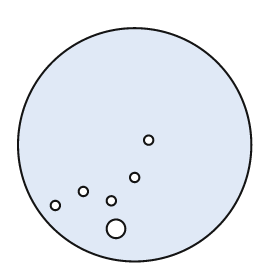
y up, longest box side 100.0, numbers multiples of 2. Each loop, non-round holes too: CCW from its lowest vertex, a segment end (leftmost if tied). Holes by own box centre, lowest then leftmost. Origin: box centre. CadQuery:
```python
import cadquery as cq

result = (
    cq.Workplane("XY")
    .moveTo(0.0, 0.0)
    .circle(50.0)
    .moveTo(-8.0, -36.0)
    .circle(4.0)
    .moveTo(-34.0, -26.0)
    .circle(2.0)
    .moveTo(-10.0, -24.0)
    .circle(2.0)
    .moveTo(-22.0, -20.0)
    .circle(2.0)
    .moveTo(0.0, -14.0)
    .circle(2.0)
    .moveTo(6.0, 2.0)
    .circle(2.0)
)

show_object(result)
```